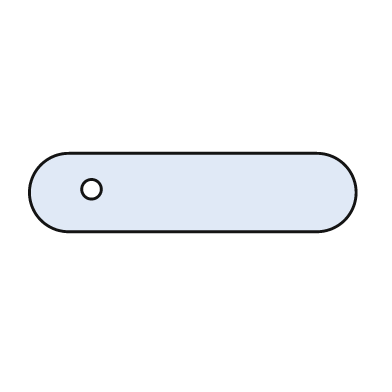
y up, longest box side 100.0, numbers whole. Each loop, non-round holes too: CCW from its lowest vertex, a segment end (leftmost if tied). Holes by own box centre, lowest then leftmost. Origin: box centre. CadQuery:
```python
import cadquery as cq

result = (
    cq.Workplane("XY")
    .moveTo(-38.0, -12.0)
    .lineTo(38.0, -12.0)
    .threePointArc((50.0, 0.0), (38.0, 12.0))
    .lineTo(-38.0, 12.0)
    .threePointArc((-50.0, 0.0), (-38.0, -12.0))
    .close()
    .moveTo(-31.0, 1.0)
    .circle(3.0)
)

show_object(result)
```